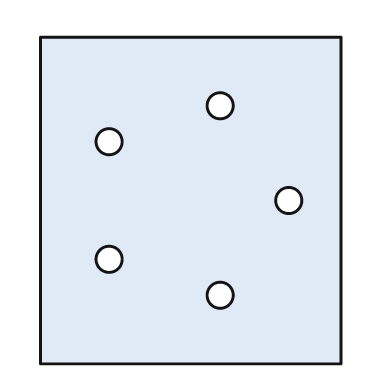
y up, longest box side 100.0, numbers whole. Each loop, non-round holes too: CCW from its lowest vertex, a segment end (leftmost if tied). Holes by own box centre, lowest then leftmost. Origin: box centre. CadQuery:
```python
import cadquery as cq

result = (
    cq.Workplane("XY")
    .moveTo(-46.0, -50.0)
    .lineTo(46.0, -50.0)
    .lineTo(46.0, 50.0)
    .lineTo(-46.0, 50.0)
    .close()
    .moveTo(9.0, -29.0)
    .circle(4.0)
    .moveTo(-25.0, -18.0)
    .circle(4.0)
    .moveTo(30.0, 0.0)
    .circle(4.0)
    .moveTo(-25.0, 18.0)
    .circle(4.0)
    .moveTo(9.0, 29.0)
    .circle(4.0)
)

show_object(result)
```